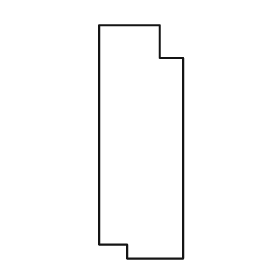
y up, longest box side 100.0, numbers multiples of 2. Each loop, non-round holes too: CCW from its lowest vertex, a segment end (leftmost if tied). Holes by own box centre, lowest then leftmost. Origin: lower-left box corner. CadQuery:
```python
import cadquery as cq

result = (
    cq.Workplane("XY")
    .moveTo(12.0, 0.0)
    .lineTo(36.0, 0.0)
    .lineTo(36.0, 86.0)
    .lineTo(26.0, 86.0)
    .lineTo(26.0, 100.0)
    .lineTo(0.0, 100.0)
    .lineTo(0.0, 6.0)
    .lineTo(12.0, 6.0)
    .close()
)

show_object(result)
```